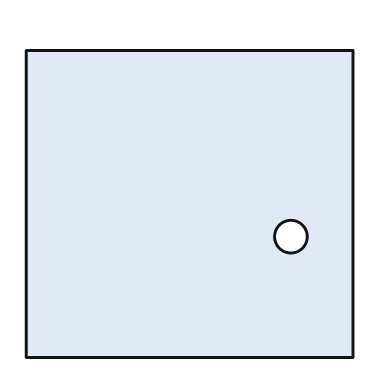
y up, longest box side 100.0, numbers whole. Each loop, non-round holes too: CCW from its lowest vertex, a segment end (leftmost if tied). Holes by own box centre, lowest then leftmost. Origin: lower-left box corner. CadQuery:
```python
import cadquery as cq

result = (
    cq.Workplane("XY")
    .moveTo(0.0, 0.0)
    .lineTo(100.0, 0.0)
    .lineTo(100.0, 94.0)
    .lineTo(0.0, 94.0)
    .close()
    .moveTo(81.0, 37.0)
    .circle(5.0)
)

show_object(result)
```